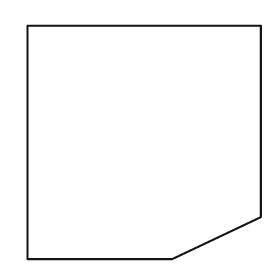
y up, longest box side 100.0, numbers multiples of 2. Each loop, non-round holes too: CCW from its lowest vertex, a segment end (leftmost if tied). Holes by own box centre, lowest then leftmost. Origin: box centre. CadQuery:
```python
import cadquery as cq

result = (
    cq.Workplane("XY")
    .moveTo(-50.0, -50.0)
    .lineTo(12.0, -50.0)
    .lineTo(50.0, -32.0)
    .lineTo(50.0, 50.0)
    .lineTo(-50.0, 50.0)
    .close()
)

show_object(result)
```